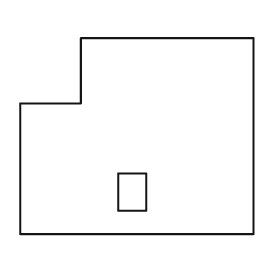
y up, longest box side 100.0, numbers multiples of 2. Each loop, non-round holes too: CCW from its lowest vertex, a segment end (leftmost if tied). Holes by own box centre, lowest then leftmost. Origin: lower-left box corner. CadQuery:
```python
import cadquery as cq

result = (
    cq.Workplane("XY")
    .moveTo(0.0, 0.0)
    .lineTo(100.0, 0.0)
    .lineTo(100.0, 84.0)
    .lineTo(26.0, 84.0)
    .lineTo(26.0, 56.0)
    .lineTo(0.0, 56.0)
    .close()
    .moveTo(42.0, 10.0)
    .lineTo(54.0, 10.0)
    .lineTo(54.0, 26.0)
    .lineTo(42.0, 26.0)
    .close()
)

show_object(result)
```